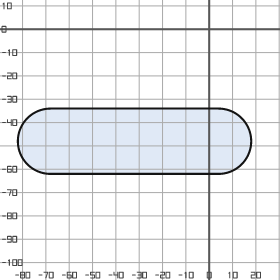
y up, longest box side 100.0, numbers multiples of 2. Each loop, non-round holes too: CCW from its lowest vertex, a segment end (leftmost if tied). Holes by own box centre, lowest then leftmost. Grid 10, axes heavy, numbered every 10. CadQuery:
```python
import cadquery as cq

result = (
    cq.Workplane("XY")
    .moveTo(-68.0, -62.0)
    .lineTo(4.0, -62.0)
    .threePointArc((18.0, -48.0), (4.0, -34.0))
    .lineTo(-68.0, -34.0)
    .threePointArc((-82.0, -48.0), (-68.0, -62.0))
    .close()
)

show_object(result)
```